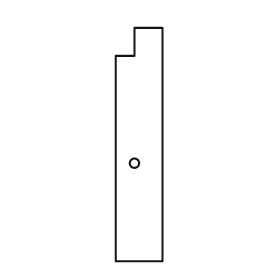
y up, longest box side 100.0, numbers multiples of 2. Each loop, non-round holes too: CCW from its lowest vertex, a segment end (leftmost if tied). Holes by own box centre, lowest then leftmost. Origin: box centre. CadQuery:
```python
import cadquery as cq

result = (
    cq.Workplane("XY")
    .moveTo(-10.0, -50.0)
    .lineTo(10.0, -50.0)
    .lineTo(10.0, 50.0)
    .lineTo(-2.0, 50.0)
    .lineTo(-2.0, 38.0)
    .lineTo(-10.0, 38.0)
    .close()
    .moveTo(-2.0, -8.0)
    .circle(2.0)
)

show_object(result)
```